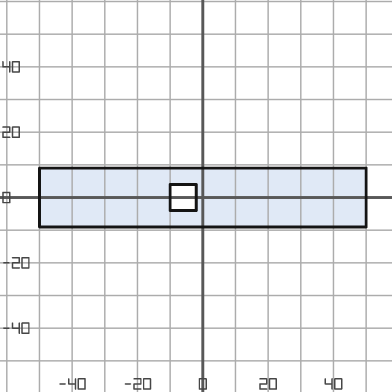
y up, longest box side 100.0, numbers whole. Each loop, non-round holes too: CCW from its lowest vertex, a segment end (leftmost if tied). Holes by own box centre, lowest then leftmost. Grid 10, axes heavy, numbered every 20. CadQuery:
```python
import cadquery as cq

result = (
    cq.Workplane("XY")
    .moveTo(-50.0, -9.0)
    .lineTo(50.0, -9.0)
    .lineTo(50.0, 9.0)
    .lineTo(-50.0, 9.0)
    .close()
    .moveTo(-10.0, -4.0)
    .lineTo(-2.0, -4.0)
    .lineTo(-2.0, 4.0)
    .lineTo(-10.0, 4.0)
    .close()
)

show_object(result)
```